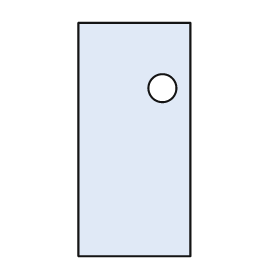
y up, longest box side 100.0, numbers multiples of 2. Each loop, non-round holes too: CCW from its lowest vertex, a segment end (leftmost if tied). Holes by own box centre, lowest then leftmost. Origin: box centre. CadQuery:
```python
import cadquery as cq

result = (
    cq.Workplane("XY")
    .moveTo(-24.0, -50.0)
    .lineTo(24.0, -50.0)
    .lineTo(24.0, 50.0)
    .lineTo(-24.0, 50.0)
    .close()
    .moveTo(12.0, 22.0)
    .circle(6.0)
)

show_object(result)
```